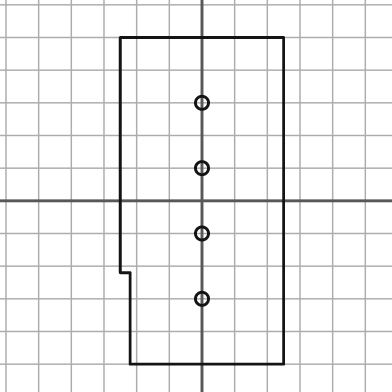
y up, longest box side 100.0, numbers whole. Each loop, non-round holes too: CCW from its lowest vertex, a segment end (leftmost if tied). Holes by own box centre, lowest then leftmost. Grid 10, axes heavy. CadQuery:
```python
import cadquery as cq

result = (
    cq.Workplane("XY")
    .moveTo(-22.0, -50.0)
    .lineTo(25.0, -50.0)
    .lineTo(25.0, 50.0)
    .lineTo(-25.0, 50.0)
    .lineTo(-25.0, -22.0)
    .lineTo(-22.0, -22.0)
    .close()
    .moveTo(0.0, -30.0)
    .circle(2.0)
    .moveTo(0.0, -10.0)
    .circle(2.0)
    .moveTo(0.0, 10.0)
    .circle(2.0)
    .moveTo(0.0, 30.0)
    .circle(2.0)
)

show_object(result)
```